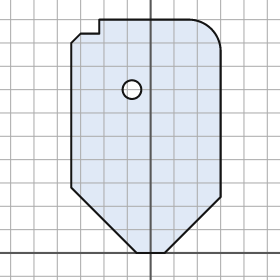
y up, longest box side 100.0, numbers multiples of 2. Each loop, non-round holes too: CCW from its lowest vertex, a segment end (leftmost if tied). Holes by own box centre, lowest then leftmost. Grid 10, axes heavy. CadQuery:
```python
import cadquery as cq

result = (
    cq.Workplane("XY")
    .moveTo(-6.0, 0.0)
    .lineTo(6.0, 0.0)
    .lineTo(30.0, 24.0)
    .lineTo(30.0, 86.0)
    .threePointArc((26.0, 96.0), (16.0, 100.0))
    .lineTo(-22.0, 100.0)
    .lineTo(-22.0, 94.0)
    .lineTo(-30.0, 94.0)
    .lineTo(-34.0, 90.0)
    .lineTo(-34.0, 28.0)
    .close()
    .moveTo(-8.0, 70.0)
    .circle(4.0)
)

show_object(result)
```